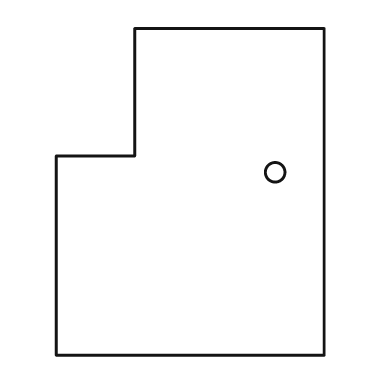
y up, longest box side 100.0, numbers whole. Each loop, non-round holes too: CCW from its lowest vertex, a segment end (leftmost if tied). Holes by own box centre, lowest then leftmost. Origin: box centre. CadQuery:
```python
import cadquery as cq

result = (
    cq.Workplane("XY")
    .moveTo(-41.0, -50.0)
    .lineTo(41.0, -50.0)
    .lineTo(41.0, 50.0)
    .lineTo(-17.0, 50.0)
    .lineTo(-17.0, 11.0)
    .lineTo(-41.0, 11.0)
    .close()
    .moveTo(26.0, 6.0)
    .circle(3.0)
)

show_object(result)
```